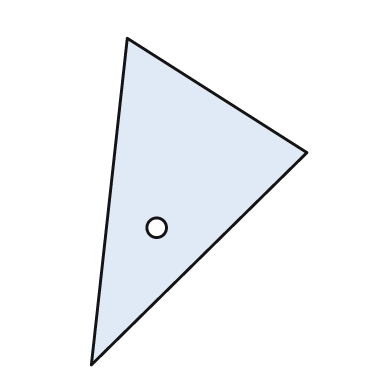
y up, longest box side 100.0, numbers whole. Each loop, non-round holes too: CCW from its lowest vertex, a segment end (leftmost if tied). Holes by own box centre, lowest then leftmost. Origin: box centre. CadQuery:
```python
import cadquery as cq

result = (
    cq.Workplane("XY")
    .moveTo(-33.0, -50.0)
    .lineTo(33.0, 15.0)
    .lineTo(-22.0, 50.0)
    .close()
    .moveTo(-13.0, -8.0)
    .circle(3.0)
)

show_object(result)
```